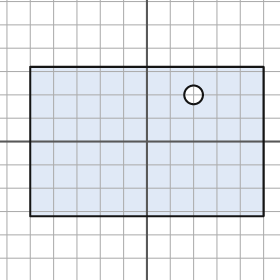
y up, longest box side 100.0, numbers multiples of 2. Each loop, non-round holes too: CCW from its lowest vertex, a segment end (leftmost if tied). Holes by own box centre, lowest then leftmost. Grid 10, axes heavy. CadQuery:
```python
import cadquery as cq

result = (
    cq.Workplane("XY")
    .moveTo(-50.0, -32.0)
    .lineTo(50.0, -32.0)
    .lineTo(50.0, 32.0)
    .lineTo(-50.0, 32.0)
    .close()
    .moveTo(20.0, 20.0)
    .circle(4.0)
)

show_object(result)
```